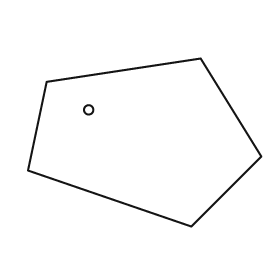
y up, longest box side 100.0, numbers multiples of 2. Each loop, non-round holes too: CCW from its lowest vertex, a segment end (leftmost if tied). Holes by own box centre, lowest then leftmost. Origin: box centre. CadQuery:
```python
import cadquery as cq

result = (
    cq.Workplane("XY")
    .moveTo(20.0, -36.0)
    .lineTo(50.0, -6.0)
    .lineTo(24.0, 36.0)
    .lineTo(-42.0, 26.0)
    .lineTo(-50.0, -12.0)
    .close()
    .moveTo(-24.0, 14.0)
    .circle(2.0)
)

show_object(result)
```